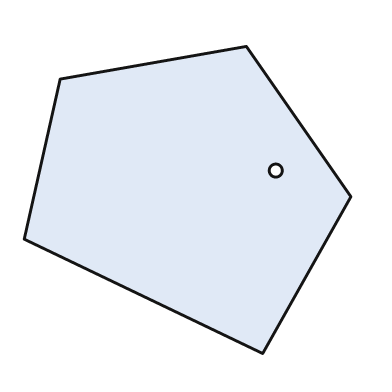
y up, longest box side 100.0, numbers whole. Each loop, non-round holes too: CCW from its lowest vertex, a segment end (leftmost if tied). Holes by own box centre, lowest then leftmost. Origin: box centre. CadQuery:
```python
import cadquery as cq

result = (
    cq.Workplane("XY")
    .moveTo(23.0, -47.0)
    .lineTo(50.0, 1.0)
    .lineTo(18.0, 47.0)
    .lineTo(-39.0, 37.0)
    .lineTo(-50.0, -12.0)
    .close()
    .moveTo(27.0, 9.0)
    .circle(2.0)
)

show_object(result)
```